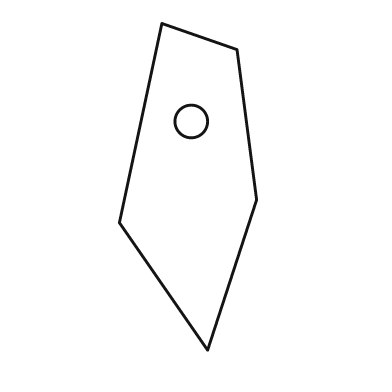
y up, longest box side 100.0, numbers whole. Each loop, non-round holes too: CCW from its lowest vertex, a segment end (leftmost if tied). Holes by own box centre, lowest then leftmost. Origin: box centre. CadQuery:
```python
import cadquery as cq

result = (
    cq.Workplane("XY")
    .moveTo(6.0, -50.0)
    .lineTo(21.0, -4.0)
    .lineTo(15.0, 42.0)
    .lineTo(-8.0, 50.0)
    .lineTo(-21.0, -11.0)
    .close()
    .moveTo(1.0, 20.0)
    .circle(5.0)
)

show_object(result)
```